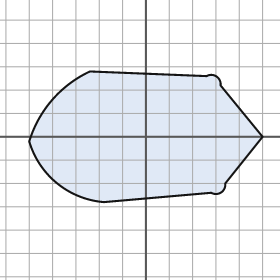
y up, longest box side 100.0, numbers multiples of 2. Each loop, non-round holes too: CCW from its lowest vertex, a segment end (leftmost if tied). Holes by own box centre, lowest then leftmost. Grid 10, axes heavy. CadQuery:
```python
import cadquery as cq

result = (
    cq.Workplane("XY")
    .moveTo(-18.0, -28.0)
    .lineTo(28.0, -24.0)
    .threePointArc((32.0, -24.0), (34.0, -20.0))
    .lineTo(50.0, 0.0)
    .lineTo(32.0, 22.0)
    .threePointArc((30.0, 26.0), (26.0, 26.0))
    .lineTo(-24.0, 28.0)
    .threePointArc((-40.0, 16.0), (-50.0, -2.0))
    .threePointArc((-38.0, -20.0), (-18.0, -28.0))
    .close()
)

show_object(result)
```